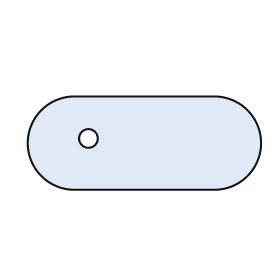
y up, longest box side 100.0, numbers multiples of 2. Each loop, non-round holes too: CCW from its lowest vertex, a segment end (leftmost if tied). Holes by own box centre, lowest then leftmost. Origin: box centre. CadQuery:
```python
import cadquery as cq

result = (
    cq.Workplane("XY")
    .moveTo(-30.0, -20.0)
    .lineTo(30.0, -20.0)
    .threePointArc((50.0, 0.0), (30.0, 20.0))
    .lineTo(-30.0, 20.0)
    .threePointArc((-50.0, 0.0), (-30.0, -20.0))
    .close()
    .moveTo(-24.0, 2.0)
    .circle(4.0)
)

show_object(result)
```